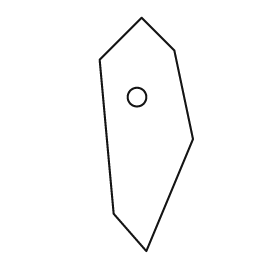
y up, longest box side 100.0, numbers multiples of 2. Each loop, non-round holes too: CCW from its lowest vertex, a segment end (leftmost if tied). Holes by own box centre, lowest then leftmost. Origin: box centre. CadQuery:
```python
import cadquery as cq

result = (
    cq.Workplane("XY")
    .moveTo(0.0, -50.0)
    .lineTo(20.0, -2.0)
    .lineTo(12.0, 36.0)
    .lineTo(-2.0, 50.0)
    .lineTo(-20.0, 32.0)
    .lineTo(-14.0, -34.0)
    .close()
    .moveTo(-4.0, 16.0)
    .circle(4.0)
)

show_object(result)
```